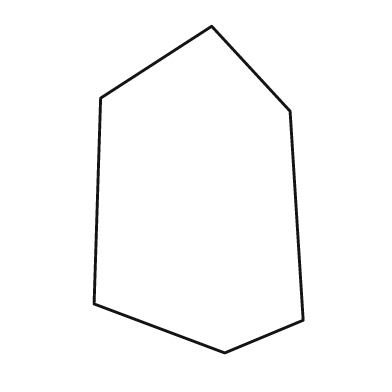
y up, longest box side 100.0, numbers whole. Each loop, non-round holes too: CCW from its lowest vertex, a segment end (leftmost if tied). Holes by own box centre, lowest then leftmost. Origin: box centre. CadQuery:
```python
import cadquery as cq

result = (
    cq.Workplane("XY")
    .moveTo(8.0, -50.0)
    .lineTo(32.0, -40.0)
    .lineTo(28.0, 24.0)
    .lineTo(4.0, 50.0)
    .lineTo(-30.0, 28.0)
    .lineTo(-32.0, -35.0)
    .close()
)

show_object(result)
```